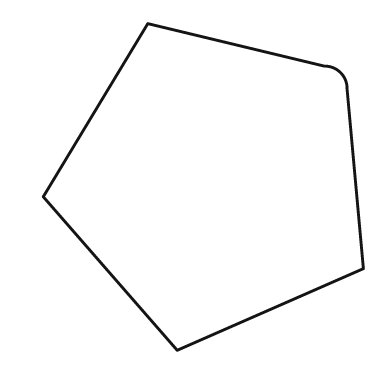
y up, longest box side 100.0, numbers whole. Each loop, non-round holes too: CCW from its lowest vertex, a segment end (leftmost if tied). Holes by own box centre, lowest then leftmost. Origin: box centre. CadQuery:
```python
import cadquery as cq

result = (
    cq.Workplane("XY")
    .moveTo(-8.0, -50.0)
    .lineTo(49.0, -25.0)
    .lineTo(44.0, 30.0)
    .threePointArc((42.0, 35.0), (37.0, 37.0))
    .lineTo(-17.0, 50.0)
    .lineTo(-49.0, -3.0)
    .close()
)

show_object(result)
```